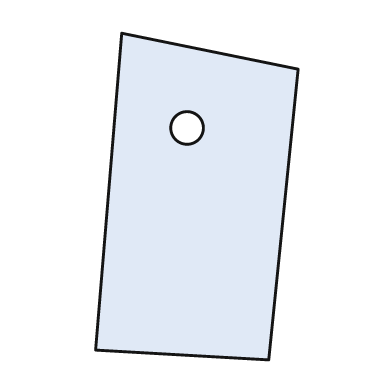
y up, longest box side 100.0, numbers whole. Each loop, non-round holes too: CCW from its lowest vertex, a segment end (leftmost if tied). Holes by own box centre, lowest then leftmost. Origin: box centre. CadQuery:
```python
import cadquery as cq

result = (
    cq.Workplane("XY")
    .moveTo(22.0, -50.0)
    .lineTo(31.0, 39.0)
    .lineTo(-23.0, 50.0)
    .lineTo(-31.0, -47.0)
    .close()
    .moveTo(-3.0, 21.0)
    .circle(5.0)
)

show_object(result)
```